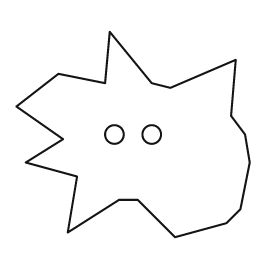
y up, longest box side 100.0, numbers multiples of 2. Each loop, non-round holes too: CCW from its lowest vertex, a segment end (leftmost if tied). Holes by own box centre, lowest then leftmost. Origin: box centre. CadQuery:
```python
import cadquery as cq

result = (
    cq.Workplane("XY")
    .moveTo(18.0, -44.0)
    .lineTo(40.0, -38.0)
    .lineTo(46.0, -32.0)
    .lineTo(50.0, -12.0)
    .lineTo(48.0, 0.0)
    .lineTo(42.0, 8.0)
    .lineTo(44.0, 32.0)
    .lineTo(16.0, 20.0)
    .lineTo(8.0, 22.0)
    .lineTo(-10.0, 44.0)
    .lineTo(-12.0, 22.0)
    .lineTo(-32.0, 26.0)
    .lineTo(-50.0, 12.0)
    .lineTo(-30.0, -2.0)
    .lineTo(-46.0, -12.0)
    .lineTo(-24.0, -18.0)
    .lineTo(-28.0, -42.0)
    .lineTo(-6.0, -28.0)
    .lineTo(2.0, -28.0)
    .close()
    .moveTo(-8.0, 0.0)
    .circle(4.0)
    .moveTo(8.0, 0.0)
    .circle(4.0)
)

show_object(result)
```